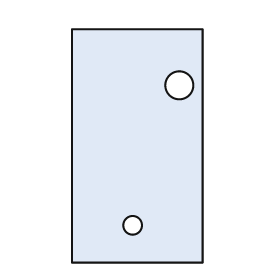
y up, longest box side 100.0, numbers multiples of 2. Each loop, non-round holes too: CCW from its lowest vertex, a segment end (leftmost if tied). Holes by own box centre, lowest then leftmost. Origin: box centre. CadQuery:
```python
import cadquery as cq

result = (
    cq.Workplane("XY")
    .moveTo(-28.0, -50.0)
    .lineTo(28.0, -50.0)
    .lineTo(28.0, 50.0)
    .lineTo(-28.0, 50.0)
    .close()
    .moveTo(-2.0, -34.0)
    .circle(4.0)
    .moveTo(18.0, 26.0)
    .circle(6.0)
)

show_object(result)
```